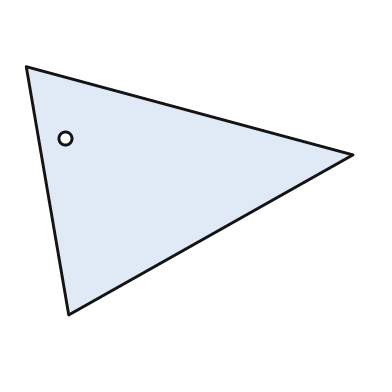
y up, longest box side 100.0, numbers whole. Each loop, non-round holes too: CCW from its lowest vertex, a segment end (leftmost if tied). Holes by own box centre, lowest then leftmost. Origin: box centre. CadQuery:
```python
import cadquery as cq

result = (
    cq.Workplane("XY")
    .moveTo(-37.0, -38.0)
    .lineTo(50.0, 11.0)
    .lineTo(-50.0, 38.0)
    .close()
    .moveTo(-38.0, 16.0)
    .circle(2.0)
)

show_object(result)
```